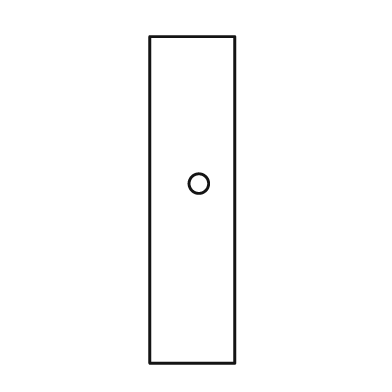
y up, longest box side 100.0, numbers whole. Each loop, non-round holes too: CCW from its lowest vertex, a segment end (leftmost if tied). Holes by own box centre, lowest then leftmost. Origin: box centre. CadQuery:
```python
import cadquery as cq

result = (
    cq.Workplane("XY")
    .moveTo(-13.0, -50.0)
    .lineTo(13.0, -50.0)
    .lineTo(13.0, 50.0)
    .lineTo(-13.0, 50.0)
    .close()
    .moveTo(2.0, 5.0)
    .circle(3.0)
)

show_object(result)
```